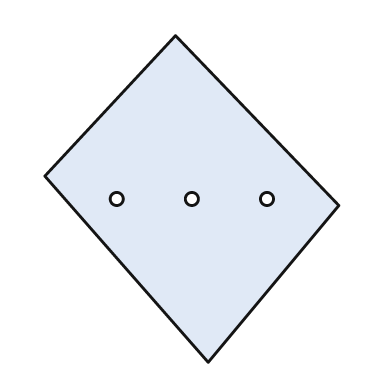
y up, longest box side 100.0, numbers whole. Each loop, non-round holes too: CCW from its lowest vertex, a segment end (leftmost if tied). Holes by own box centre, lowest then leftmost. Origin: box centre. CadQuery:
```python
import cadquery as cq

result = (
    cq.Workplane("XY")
    .moveTo(5.0, -50.0)
    .lineTo(45.0, -2.0)
    .lineTo(-5.0, 50.0)
    .lineTo(-45.0, 7.0)
    .close()
    .moveTo(-23.0, 0.0)
    .circle(2.0)
    .moveTo(0.0, 0.0)
    .circle(2.0)
    .moveTo(23.0, 0.0)
    .circle(2.0)
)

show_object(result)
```